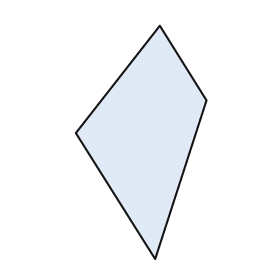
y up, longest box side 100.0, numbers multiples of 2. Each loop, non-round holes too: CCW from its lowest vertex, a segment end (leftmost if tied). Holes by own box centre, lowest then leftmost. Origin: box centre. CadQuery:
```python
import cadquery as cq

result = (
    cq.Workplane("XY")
    .moveTo(6.0, -50.0)
    .lineTo(28.0, 18.0)
    .lineTo(8.0, 50.0)
    .lineTo(-28.0, 4.0)
    .close()
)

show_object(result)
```